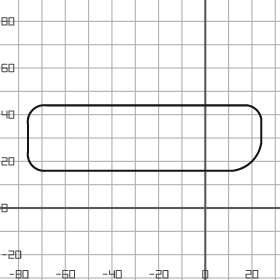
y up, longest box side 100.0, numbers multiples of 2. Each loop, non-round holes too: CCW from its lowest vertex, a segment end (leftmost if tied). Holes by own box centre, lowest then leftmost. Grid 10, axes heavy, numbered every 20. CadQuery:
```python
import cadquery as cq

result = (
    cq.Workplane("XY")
    .moveTo(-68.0, 16.0)
    .lineTo(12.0, 16.0)
    .threePointArc((20.0, 20.0), (24.0, 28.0))
    .lineTo(24.0, 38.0)
    .threePointArc((22.0, 42.0), (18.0, 44.0))
    .lineTo(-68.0, 44.0)
    .threePointArc((-74.0, 42.0), (-76.0, 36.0))
    .lineTo(-76.0, 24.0)
    .threePointArc((-74.0, 18.0), (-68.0, 16.0))
    .close()
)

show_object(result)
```